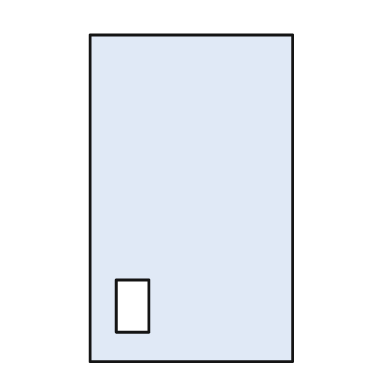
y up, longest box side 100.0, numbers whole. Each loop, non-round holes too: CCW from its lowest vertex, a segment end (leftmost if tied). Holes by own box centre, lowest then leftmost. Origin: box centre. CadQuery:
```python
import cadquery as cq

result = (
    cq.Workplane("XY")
    .moveTo(-31.0, -50.0)
    .lineTo(31.0, -50.0)
    .lineTo(31.0, 50.0)
    .lineTo(-31.0, 50.0)
    .close()
    .moveTo(-23.0, -41.0)
    .lineTo(-13.0, -41.0)
    .lineTo(-13.0, -25.0)
    .lineTo(-23.0, -25.0)
    .close()
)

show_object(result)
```